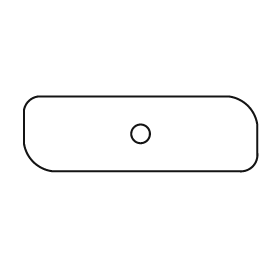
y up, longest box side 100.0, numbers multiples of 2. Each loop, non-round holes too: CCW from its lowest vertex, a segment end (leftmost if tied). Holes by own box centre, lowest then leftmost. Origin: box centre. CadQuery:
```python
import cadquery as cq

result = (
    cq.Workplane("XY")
    .moveTo(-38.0, -16.0)
    .lineTo(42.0, -16.0)
    .threePointArc((48.0, -14.0), (50.0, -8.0))
    .lineTo(50.0, 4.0)
    .threePointArc((46.0, 12.0), (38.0, 16.0))
    .lineTo(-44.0, 16.0)
    .threePointArc((-48.0, 14.0), (-50.0, 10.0))
    .lineTo(-50.0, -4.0)
    .threePointArc((-46.0, -12.0), (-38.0, -16.0))
    .close()
    .moveTo(0.0, 0.0)
    .circle(4.0)
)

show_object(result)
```